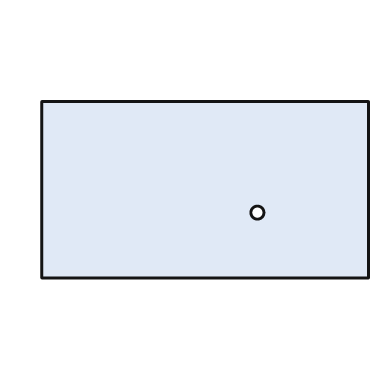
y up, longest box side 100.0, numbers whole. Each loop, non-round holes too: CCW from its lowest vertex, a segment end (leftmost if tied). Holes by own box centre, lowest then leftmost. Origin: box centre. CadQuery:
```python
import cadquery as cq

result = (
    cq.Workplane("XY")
    .moveTo(-50.0, -27.0)
    .lineTo(50.0, -27.0)
    .lineTo(50.0, 27.0)
    .lineTo(-50.0, 27.0)
    .close()
    .moveTo(16.0, -7.0)
    .circle(2.0)
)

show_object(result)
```